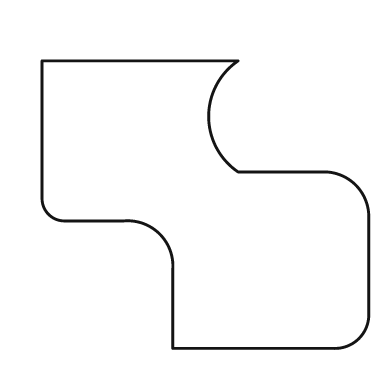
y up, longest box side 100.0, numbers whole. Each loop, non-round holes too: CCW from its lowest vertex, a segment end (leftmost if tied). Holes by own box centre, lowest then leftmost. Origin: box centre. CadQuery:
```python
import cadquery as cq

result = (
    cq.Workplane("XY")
    .moveTo(-10.0, -44.0)
    .lineTo(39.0, -44.0)
    .threePointArc((47.0, -41.0), (50.0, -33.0))
    .lineTo(50.0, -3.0)
    .threePointArc((46.0, 6.0), (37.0, 10.0))
    .lineTo(10.0, 10.0)
    .threePointArc((1.0, 27.0), (10.0, 44.0))
    .lineTo(-50.0, 44.0)
    .lineTo(-50.0, 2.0)
    .threePointArc((-48.0, -3.0), (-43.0, -5.0))
    .lineTo(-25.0, -5.0)
    .threePointArc((-14.0, -9.0), (-10.0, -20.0))
    .close()
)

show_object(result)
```